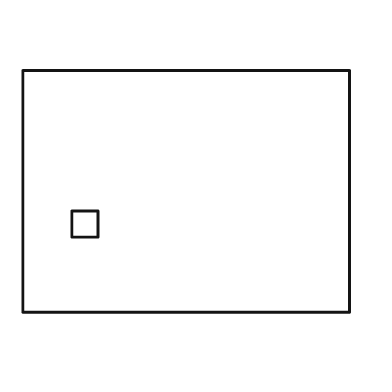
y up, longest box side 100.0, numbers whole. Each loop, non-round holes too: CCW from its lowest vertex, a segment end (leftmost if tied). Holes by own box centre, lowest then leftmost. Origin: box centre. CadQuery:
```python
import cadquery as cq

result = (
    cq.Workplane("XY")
    .moveTo(-50.0, -37.0)
    .lineTo(50.0, -37.0)
    .lineTo(50.0, 37.0)
    .lineTo(-50.0, 37.0)
    .close()
    .moveTo(-35.0, -14.0)
    .lineTo(-27.0, -14.0)
    .lineTo(-27.0, -6.0)
    .lineTo(-35.0, -6.0)
    .close()
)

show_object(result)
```